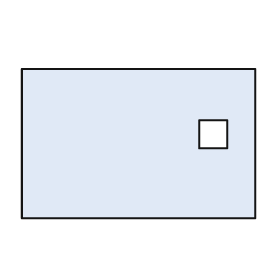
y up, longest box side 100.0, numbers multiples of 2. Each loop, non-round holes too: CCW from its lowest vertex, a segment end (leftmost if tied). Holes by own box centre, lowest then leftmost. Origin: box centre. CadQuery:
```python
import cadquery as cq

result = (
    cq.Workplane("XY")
    .moveTo(-50.0, -32.0)
    .lineTo(50.0, -32.0)
    .lineTo(50.0, 32.0)
    .lineTo(-50.0, 32.0)
    .close()
    .moveTo(26.0, -2.0)
    .lineTo(38.0, -2.0)
    .lineTo(38.0, 10.0)
    .lineTo(26.0, 10.0)
    .close()
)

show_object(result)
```